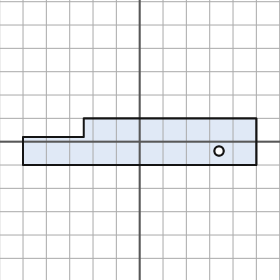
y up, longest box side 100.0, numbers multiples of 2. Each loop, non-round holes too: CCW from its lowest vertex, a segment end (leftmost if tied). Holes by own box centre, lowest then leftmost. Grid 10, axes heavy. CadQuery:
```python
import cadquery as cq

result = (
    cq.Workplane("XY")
    .moveTo(-50.0, -10.0)
    .lineTo(50.0, -10.0)
    .lineTo(50.0, 10.0)
    .lineTo(-24.0, 10.0)
    .lineTo(-24.0, 2.0)
    .lineTo(-50.0, 2.0)
    .close()
    .moveTo(34.0, -4.0)
    .circle(2.0)
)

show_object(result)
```